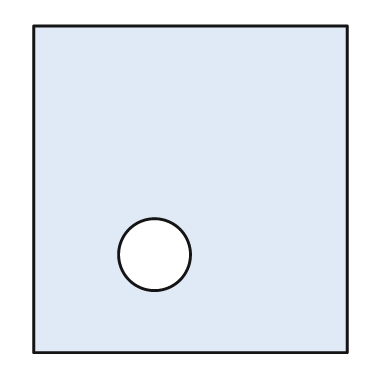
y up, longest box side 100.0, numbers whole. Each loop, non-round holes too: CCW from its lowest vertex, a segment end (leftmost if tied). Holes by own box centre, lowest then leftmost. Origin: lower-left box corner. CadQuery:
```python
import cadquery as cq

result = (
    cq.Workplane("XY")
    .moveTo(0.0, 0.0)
    .lineTo(96.0, 0.0)
    .lineTo(96.0, 100.0)
    .lineTo(0.0, 100.0)
    .close()
    .moveTo(37.0, 30.0)
    .circle(11.0)
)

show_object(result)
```